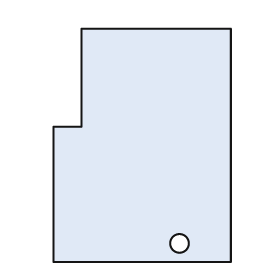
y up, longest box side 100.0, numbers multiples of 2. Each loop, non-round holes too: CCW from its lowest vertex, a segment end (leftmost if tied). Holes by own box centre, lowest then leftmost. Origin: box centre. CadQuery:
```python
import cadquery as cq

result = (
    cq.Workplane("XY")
    .moveTo(-38.0, -50.0)
    .lineTo(38.0, -50.0)
    .lineTo(38.0, 50.0)
    .lineTo(-26.0, 50.0)
    .lineTo(-26.0, 8.0)
    .lineTo(-38.0, 8.0)
    .close()
    .moveTo(16.0, -42.0)
    .circle(4.0)
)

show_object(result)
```